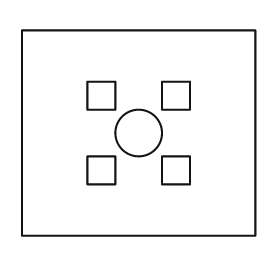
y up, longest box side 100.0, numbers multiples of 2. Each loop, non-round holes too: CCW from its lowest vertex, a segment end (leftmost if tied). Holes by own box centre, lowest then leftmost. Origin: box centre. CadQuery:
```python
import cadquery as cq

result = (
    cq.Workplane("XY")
    .moveTo(-50.0, -44.0)
    .lineTo(50.0, -44.0)
    .lineTo(50.0, 44.0)
    .lineTo(-50.0, 44.0)
    .close()
    .moveTo(-22.0, -22.0)
    .lineTo(-10.0, -22.0)
    .lineTo(-10.0, -10.0)
    .lineTo(-22.0, -10.0)
    .close()
    .moveTo(10.0, -22.0)
    .lineTo(22.0, -22.0)
    .lineTo(22.0, -10.0)
    .lineTo(10.0, -10.0)
    .close()
    .moveTo(0.0, 0.0)
    .circle(10.0)
    .moveTo(-22.0, 10.0)
    .lineTo(-10.0, 10.0)
    .lineTo(-10.0, 22.0)
    .lineTo(-22.0, 22.0)
    .close()
    .moveTo(10.0, 10.0)
    .lineTo(22.0, 10.0)
    .lineTo(22.0, 22.0)
    .lineTo(10.0, 22.0)
    .close()
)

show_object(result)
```